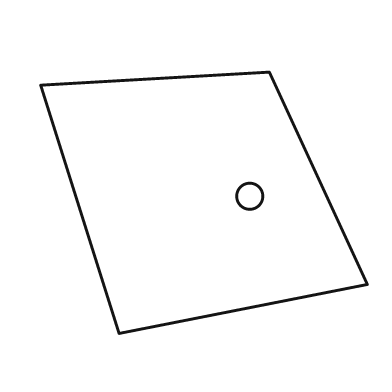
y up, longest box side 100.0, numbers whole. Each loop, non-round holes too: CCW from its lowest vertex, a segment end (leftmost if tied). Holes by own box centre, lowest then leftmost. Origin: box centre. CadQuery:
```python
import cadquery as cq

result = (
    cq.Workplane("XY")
    .moveTo(-26.0, -40.0)
    .lineTo(50.0, -25.0)
    .lineTo(20.0, 40.0)
    .lineTo(-50.0, 36.0)
    .close()
    .moveTo(14.0, 2.0)
    .circle(4.0)
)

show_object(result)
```